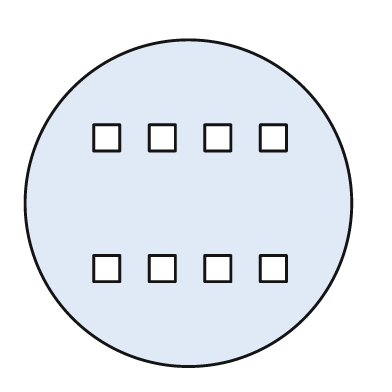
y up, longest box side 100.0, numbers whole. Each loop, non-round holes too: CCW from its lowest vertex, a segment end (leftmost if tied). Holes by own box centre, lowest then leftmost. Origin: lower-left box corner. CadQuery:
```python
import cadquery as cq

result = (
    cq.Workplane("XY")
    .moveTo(50.0, 50.0)
    .circle(50.0)
    .moveTo(21.0, 26.0)
    .lineTo(29.0, 26.0)
    .lineTo(29.0, 34.0)
    .lineTo(21.0, 34.0)
    .close()
    .moveTo(38.0, 26.0)
    .lineTo(46.0, 26.0)
    .lineTo(46.0, 34.0)
    .lineTo(38.0, 34.0)
    .close()
    .moveTo(55.0, 26.0)
    .lineTo(63.0, 26.0)
    .lineTo(63.0, 34.0)
    .lineTo(55.0, 34.0)
    .close()
    .moveTo(72.0, 26.0)
    .lineTo(80.0, 26.0)
    .lineTo(80.0, 34.0)
    .lineTo(72.0, 34.0)
    .close()
    .moveTo(21.0, 66.0)
    .lineTo(29.0, 66.0)
    .lineTo(29.0, 74.0)
    .lineTo(21.0, 74.0)
    .close()
    .moveTo(38.0, 66.0)
    .lineTo(46.0, 66.0)
    .lineTo(46.0, 74.0)
    .lineTo(38.0, 74.0)
    .close()
    .moveTo(55.0, 66.0)
    .lineTo(63.0, 66.0)
    .lineTo(63.0, 74.0)
    .lineTo(55.0, 74.0)
    .close()
    .moveTo(72.0, 66.0)
    .lineTo(80.0, 66.0)
    .lineTo(80.0, 74.0)
    .lineTo(72.0, 74.0)
    .close()
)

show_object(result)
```